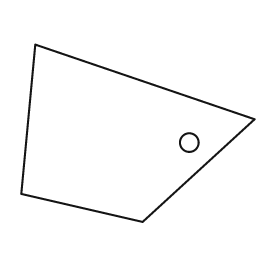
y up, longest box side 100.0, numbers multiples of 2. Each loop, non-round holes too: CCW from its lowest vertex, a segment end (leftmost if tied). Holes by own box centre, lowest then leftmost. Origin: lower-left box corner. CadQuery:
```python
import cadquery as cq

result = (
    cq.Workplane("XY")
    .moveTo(52.0, 0.0)
    .lineTo(100.0, 44.0)
    .lineTo(6.0, 76.0)
    .lineTo(0.0, 12.0)
    .close()
    .moveTo(72.0, 34.0)
    .circle(4.0)
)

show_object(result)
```